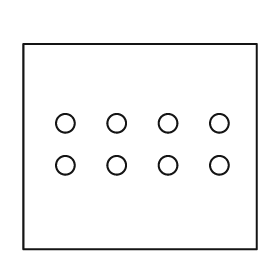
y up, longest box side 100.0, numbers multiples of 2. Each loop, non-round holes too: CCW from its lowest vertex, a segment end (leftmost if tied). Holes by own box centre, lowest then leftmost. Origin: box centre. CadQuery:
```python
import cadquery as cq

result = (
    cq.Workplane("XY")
    .moveTo(-50.0, -44.0)
    .lineTo(50.0, -44.0)
    .lineTo(50.0, 44.0)
    .lineTo(-50.0, 44.0)
    .close()
    .moveTo(-32.0, -8.0)
    .circle(4.0)
    .moveTo(-10.0, -8.0)
    .circle(4.0)
    .moveTo(12.0, -8.0)
    .circle(4.0)
    .moveTo(34.0, -8.0)
    .circle(4.0)
    .moveTo(-32.0, 10.0)
    .circle(4.0)
    .moveTo(-10.0, 10.0)
    .circle(4.0)
    .moveTo(12.0, 10.0)
    .circle(4.0)
    .moveTo(34.0, 10.0)
    .circle(4.0)
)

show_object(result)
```